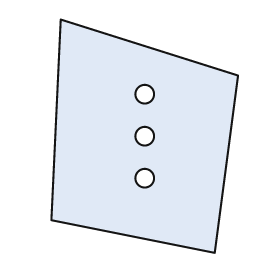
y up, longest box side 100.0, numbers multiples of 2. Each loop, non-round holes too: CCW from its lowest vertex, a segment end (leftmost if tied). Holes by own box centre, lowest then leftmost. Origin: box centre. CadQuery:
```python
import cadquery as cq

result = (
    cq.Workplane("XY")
    .moveTo(30.0, -50.0)
    .lineTo(40.0, 26.0)
    .lineTo(-36.0, 50.0)
    .lineTo(-40.0, -36.0)
    .close()
    .moveTo(0.0, -18.0)
    .circle(4.0)
    .moveTo(0.0, 0.0)
    .circle(4.0)
    .moveTo(0.0, 18.0)
    .circle(4.0)
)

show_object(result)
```